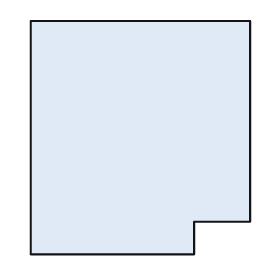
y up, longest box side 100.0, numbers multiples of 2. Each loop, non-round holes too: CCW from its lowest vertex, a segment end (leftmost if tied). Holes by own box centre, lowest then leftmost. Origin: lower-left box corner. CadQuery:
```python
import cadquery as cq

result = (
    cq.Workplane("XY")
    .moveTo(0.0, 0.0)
    .lineTo(70.0, 0.0)
    .lineTo(70.0, 14.0)
    .lineTo(94.0, 14.0)
    .lineTo(94.0, 100.0)
    .lineTo(0.0, 100.0)
    .close()
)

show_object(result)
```